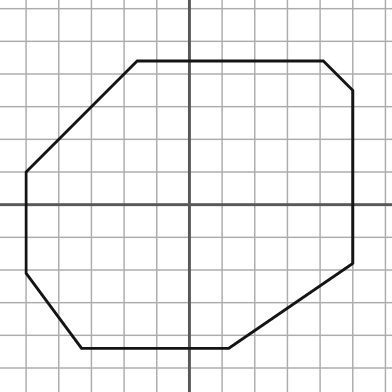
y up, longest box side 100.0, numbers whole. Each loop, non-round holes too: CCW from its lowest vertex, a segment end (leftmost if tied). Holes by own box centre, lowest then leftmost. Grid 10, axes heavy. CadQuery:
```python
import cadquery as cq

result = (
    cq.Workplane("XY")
    .moveTo(-33.0, -44.0)
    .lineTo(12.0, -44.0)
    .lineTo(50.0, -18.0)
    .lineTo(50.0, 35.0)
    .lineTo(41.0, 44.0)
    .lineTo(-16.0, 44.0)
    .lineTo(-50.0, 10.0)
    .lineTo(-50.0, -21.0)
    .close()
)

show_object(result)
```